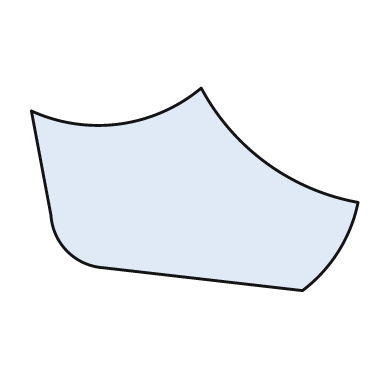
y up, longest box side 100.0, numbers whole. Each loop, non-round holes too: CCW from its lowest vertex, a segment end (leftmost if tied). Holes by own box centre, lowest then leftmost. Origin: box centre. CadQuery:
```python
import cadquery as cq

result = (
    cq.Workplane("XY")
    .moveTo(33.0, -31.0)
    .threePointArc((44.0, -19.0), (50.0, -4.0))
    .threePointArc((22.0, 8.0), (2.0, 31.0))
    .threePointArc((-23.0, 20.0), (-50.0, 24.0))
    .lineTo(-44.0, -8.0)
    .threePointArc((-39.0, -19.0), (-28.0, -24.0))
    .close()
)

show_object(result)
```